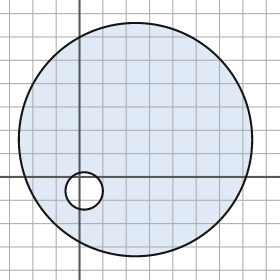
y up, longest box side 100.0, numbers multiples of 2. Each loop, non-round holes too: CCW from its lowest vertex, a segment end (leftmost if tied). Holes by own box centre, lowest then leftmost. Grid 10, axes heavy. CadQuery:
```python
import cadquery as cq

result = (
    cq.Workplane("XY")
    .moveTo(24.0, 16.0)
    .circle(50.0)
    .moveTo(2.0, -6.0)
    .circle(8.0)
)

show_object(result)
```